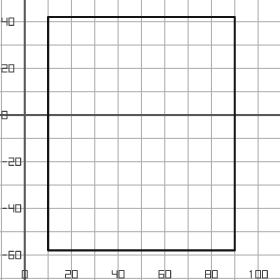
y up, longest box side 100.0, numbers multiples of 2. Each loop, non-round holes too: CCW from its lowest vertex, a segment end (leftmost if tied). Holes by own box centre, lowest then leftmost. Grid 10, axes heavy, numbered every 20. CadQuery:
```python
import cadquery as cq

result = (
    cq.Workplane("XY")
    .moveTo(10.0, -58.0)
    .lineTo(90.0, -58.0)
    .lineTo(90.0, 42.0)
    .lineTo(10.0, 42.0)
    .close()
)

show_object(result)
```